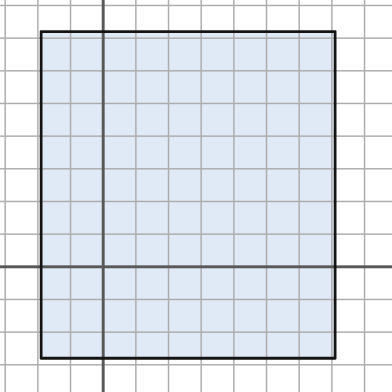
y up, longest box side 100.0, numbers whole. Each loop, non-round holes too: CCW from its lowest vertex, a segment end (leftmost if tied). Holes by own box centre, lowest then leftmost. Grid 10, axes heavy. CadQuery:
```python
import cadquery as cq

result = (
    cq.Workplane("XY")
    .moveTo(-19.0, -28.0)
    .lineTo(71.0, -28.0)
    .lineTo(71.0, 72.0)
    .lineTo(-19.0, 72.0)
    .close()
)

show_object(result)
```